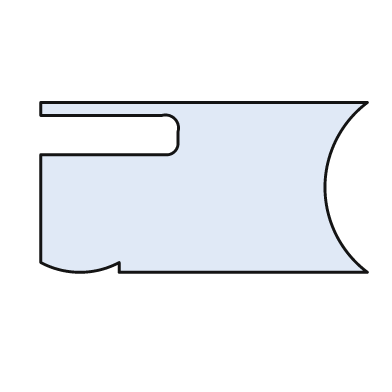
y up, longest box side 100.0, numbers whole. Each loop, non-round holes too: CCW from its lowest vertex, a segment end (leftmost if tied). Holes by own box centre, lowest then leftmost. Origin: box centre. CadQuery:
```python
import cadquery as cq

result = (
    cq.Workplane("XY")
    .moveTo(-26.0, -26.0)
    .lineTo(50.0, -26.0)
    .threePointArc((37.0, 0.0), (50.0, 26.0))
    .lineTo(-50.0, 26.0)
    .lineTo(-50.0, 22.0)
    .lineTo(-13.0, 22.0)
    .threePointArc((-9.0, 21.0), (-8.0, 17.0))
    .lineTo(-8.0, 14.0)
    .threePointArc((-9.0, 11.0), (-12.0, 10.0))
    .lineTo(-50.0, 10.0)
    .lineTo(-50.0, -23.0)
    .threePointArc((-38.0, -26.0), (-26.0, -23.0))
    .close()
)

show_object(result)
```